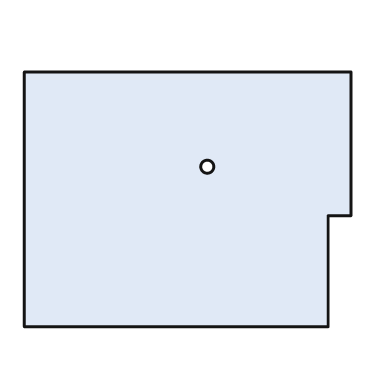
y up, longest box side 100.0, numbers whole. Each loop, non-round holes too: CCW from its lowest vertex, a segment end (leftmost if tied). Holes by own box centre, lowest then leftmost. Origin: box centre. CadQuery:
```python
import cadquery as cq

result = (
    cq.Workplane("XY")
    .moveTo(-50.0, -39.0)
    .lineTo(43.0, -39.0)
    .lineTo(43.0, -5.0)
    .lineTo(50.0, -5.0)
    .lineTo(50.0, 39.0)
    .lineTo(-50.0, 39.0)
    .close()
    .moveTo(6.0, 10.0)
    .circle(2.0)
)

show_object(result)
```